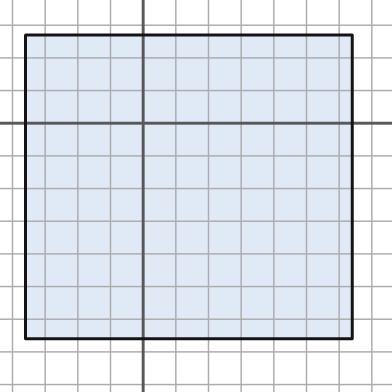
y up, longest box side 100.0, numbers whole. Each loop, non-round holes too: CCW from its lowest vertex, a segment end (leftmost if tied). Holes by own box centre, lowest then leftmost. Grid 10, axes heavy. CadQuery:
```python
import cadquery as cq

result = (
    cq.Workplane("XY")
    .moveTo(-36.0, -66.0)
    .lineTo(64.0, -66.0)
    .lineTo(64.0, 27.0)
    .lineTo(-36.0, 27.0)
    .close()
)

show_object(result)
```